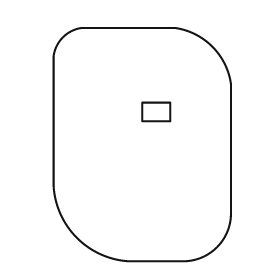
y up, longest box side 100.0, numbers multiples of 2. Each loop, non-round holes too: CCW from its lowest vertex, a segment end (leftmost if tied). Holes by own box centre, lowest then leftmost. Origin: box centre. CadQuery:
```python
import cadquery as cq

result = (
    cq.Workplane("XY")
    .moveTo(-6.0, -50.0)
    .lineTo(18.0, -50.0)
    .threePointArc((32.0, -44.0), (38.0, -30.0))
    .lineTo(38.0, 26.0)
    .threePointArc((30.0, 42.0), (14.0, 50.0))
    .lineTo(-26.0, 50.0)
    .threePointArc((-34.0, 46.0), (-38.0, 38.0))
    .lineTo(-38.0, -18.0)
    .threePointArc((-28.0, -40.0), (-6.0, -50.0))
    .close()
    .moveTo(0.0, 10.0)
    .lineTo(12.0, 10.0)
    .lineTo(12.0, 18.0)
    .lineTo(0.0, 18.0)
    .close()
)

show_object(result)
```